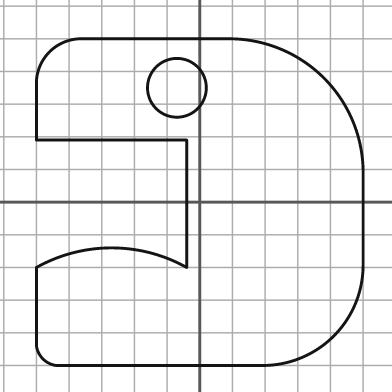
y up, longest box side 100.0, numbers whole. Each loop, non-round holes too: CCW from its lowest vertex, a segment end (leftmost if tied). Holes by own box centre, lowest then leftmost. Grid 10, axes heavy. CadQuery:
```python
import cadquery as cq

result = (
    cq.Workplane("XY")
    .moveTo(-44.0, -50.0)
    .lineTo(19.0, -50.0)
    .threePointArc((41.0, -41.0), (50.0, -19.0))
    .lineTo(50.0, 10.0)
    .threePointArc((38.0, 38.0), (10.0, 50.0))
    .lineTo(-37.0, 50.0)
    .threePointArc((-46.0, 46.0), (-50.0, 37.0))
    .lineTo(-50.0, 19.0)
    .lineTo(-4.0, 19.0)
    .lineTo(-4.0, -20.0)
    .threePointArc((-27.0, -14.0), (-50.0, -20.0))
    .lineTo(-50.0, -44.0)
    .threePointArc((-48.0, -48.0), (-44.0, -50.0))
    .close()
    .moveTo(-7.0, 35.0)
    .circle(9.0)
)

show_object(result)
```